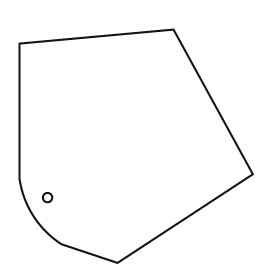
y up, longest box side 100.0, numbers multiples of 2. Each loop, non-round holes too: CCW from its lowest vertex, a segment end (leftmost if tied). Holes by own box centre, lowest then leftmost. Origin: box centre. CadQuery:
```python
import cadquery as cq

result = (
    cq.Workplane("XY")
    .moveTo(-8.0, -50.0)
    .lineTo(50.0, -12.0)
    .lineTo(16.0, 50.0)
    .lineTo(-50.0, 44.0)
    .lineTo(-50.0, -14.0)
    .threePointArc((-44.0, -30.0), (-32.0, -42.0))
    .close()
    .moveTo(-38.0, -22.0)
    .circle(2.0)
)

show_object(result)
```